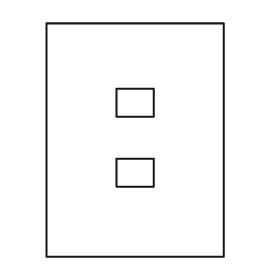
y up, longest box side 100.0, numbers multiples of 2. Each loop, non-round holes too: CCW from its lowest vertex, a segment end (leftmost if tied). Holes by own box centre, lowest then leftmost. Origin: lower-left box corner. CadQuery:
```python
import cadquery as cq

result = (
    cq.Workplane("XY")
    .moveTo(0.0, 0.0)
    .lineTo(76.0, 0.0)
    .lineTo(76.0, 100.0)
    .lineTo(0.0, 100.0)
    .close()
    .moveTo(30.0, 30.0)
    .lineTo(46.0, 30.0)
    .lineTo(46.0, 42.0)
    .lineTo(30.0, 42.0)
    .close()
    .moveTo(30.0, 60.0)
    .lineTo(46.0, 60.0)
    .lineTo(46.0, 72.0)
    .lineTo(30.0, 72.0)
    .close()
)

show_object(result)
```